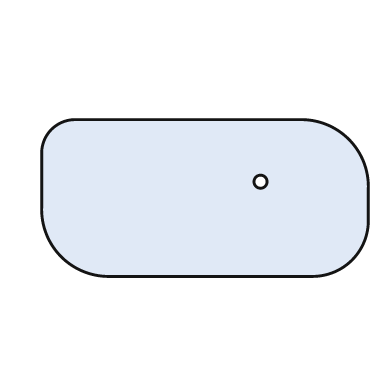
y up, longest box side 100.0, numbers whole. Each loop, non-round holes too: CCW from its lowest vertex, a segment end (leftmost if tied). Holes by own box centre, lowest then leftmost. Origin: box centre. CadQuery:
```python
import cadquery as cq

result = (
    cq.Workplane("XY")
    .moveTo(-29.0, -24.0)
    .lineTo(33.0, -24.0)
    .threePointArc((45.0, -19.0), (50.0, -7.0))
    .lineTo(50.0, 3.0)
    .threePointArc((44.0, 18.0), (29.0, 24.0))
    .lineTo(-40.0, 24.0)
    .threePointArc((-47.0, 21.0), (-50.0, 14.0))
    .lineTo(-50.0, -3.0)
    .threePointArc((-44.0, -18.0), (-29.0, -24.0))
    .close()
    .moveTo(17.0, 5.0)
    .circle(2.0)
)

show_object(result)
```